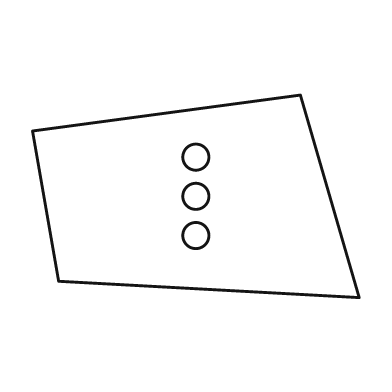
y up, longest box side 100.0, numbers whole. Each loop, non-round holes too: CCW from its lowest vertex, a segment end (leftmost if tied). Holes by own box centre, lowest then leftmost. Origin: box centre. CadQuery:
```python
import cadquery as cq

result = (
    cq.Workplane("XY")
    .moveTo(50.0, -31.0)
    .lineTo(32.0, 31.0)
    .lineTo(-50.0, 20.0)
    .lineTo(-42.0, -26.0)
    .close()
    .moveTo(0.0, -12.0)
    .circle(4.0)
    .moveTo(0.0, 0.0)
    .circle(4.0)
    .moveTo(0.0, 12.0)
    .circle(4.0)
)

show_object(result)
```